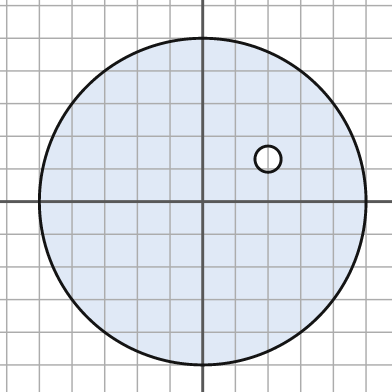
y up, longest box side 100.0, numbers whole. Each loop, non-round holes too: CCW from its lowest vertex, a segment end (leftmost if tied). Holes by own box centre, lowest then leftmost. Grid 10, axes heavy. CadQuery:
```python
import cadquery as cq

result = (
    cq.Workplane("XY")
    .moveTo(0.0, 0.0)
    .circle(50.0)
    .moveTo(20.0, 13.0)
    .circle(4.0)
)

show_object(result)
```